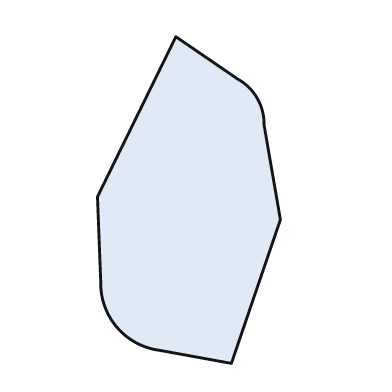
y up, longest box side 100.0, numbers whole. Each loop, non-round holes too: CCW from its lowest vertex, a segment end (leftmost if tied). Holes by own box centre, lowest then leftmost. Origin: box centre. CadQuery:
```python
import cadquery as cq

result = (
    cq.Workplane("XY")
    .moveTo(13.0, -50.0)
    .lineTo(28.0, -6.0)
    .lineTo(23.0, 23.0)
    .threePointArc((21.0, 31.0), (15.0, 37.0))
    .lineTo(-4.0, 50.0)
    .lineTo(-28.0, 1.0)
    .lineTo(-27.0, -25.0)
    .threePointArc((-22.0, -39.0), (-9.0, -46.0))
    .close()
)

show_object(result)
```